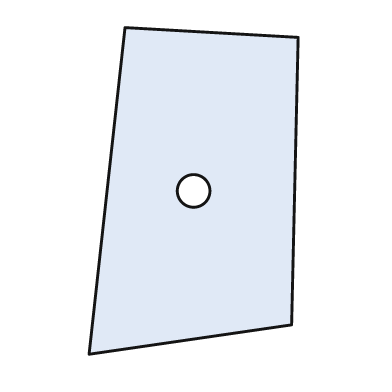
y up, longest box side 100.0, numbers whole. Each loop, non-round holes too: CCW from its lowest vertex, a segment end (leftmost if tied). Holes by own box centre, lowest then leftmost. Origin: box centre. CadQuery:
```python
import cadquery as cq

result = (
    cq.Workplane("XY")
    .moveTo(-32.0, -50.0)
    .lineTo(30.0, -41.0)
    .lineTo(32.0, 47.0)
    .lineTo(-21.0, 50.0)
    .close()
    .moveTo(0.0, 0.0)
    .circle(5.0)
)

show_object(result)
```